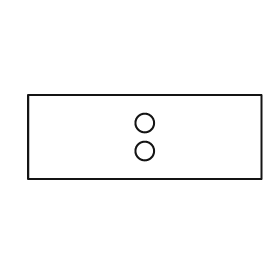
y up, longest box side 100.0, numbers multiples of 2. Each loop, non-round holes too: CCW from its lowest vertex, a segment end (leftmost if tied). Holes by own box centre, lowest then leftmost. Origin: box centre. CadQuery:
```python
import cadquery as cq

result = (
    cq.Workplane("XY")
    .moveTo(-50.0, -18.0)
    .lineTo(50.0, -18.0)
    .lineTo(50.0, 18.0)
    .lineTo(-50.0, 18.0)
    .close()
    .moveTo(0.0, -6.0)
    .circle(4.0)
    .moveTo(0.0, 6.0)
    .circle(4.0)
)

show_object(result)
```